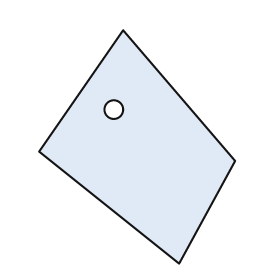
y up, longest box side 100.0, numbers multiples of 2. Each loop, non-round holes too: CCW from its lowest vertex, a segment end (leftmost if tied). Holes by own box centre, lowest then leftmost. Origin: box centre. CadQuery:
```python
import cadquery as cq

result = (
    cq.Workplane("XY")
    .moveTo(18.0, -50.0)
    .lineTo(42.0, -6.0)
    .lineTo(-6.0, 50.0)
    .lineTo(-42.0, -2.0)
    .close()
    .moveTo(-10.0, 16.0)
    .circle(4.0)
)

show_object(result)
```